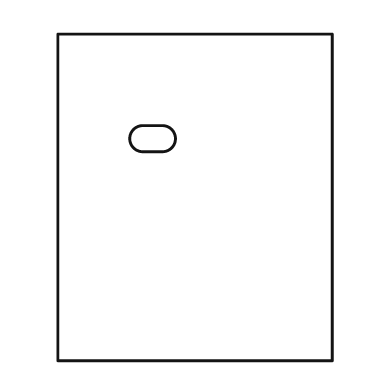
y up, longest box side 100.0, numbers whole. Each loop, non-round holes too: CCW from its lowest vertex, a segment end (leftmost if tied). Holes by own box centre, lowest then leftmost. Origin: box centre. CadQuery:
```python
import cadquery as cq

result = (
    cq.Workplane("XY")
    .moveTo(-42.0, -50.0)
    .lineTo(42.0, -50.0)
    .lineTo(42.0, 50.0)
    .lineTo(-42.0, 50.0)
    .close()
    .moveTo(-16.0, 14.0)
    .lineTo(-10.0, 14.0)
    .threePointArc((-6.0, 18.0), (-10.0, 22.0))
    .lineTo(-16.0, 22.0)
    .threePointArc((-20.0, 18.0), (-16.0, 14.0))
    .close()
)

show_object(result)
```